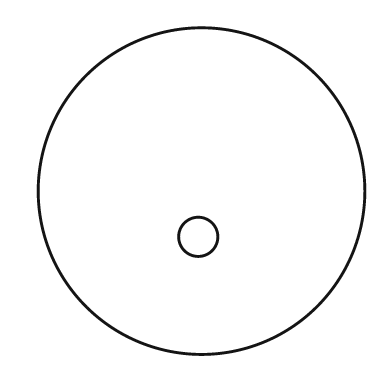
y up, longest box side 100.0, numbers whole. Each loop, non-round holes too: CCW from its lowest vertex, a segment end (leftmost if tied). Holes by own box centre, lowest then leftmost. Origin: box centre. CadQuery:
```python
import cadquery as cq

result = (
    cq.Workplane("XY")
    .moveTo(0.0, 0.0)
    .circle(50.0)
    .moveTo(-1.0, -14.0)
    .circle(6.0)
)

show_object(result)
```